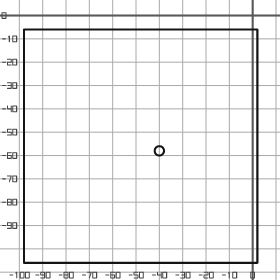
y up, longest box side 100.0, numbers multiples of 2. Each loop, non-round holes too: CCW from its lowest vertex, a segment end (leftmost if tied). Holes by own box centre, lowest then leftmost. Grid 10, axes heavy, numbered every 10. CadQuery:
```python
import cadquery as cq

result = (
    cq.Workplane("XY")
    .moveTo(-98.0, -106.0)
    .lineTo(2.0, -106.0)
    .lineTo(2.0, -6.0)
    .lineTo(-98.0, -6.0)
    .close()
    .moveTo(-40.0, -58.0)
    .circle(2.0)
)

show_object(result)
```